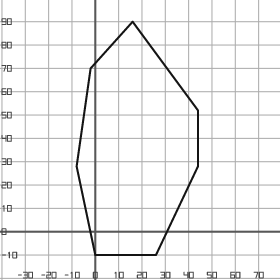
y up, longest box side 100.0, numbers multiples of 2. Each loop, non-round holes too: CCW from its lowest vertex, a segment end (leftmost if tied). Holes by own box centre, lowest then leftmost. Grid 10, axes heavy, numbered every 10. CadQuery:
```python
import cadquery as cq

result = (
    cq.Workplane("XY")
    .moveTo(0.0, -10.0)
    .lineTo(26.0, -10.0)
    .lineTo(44.0, 28.0)
    .lineTo(44.0, 52.0)
    .lineTo(16.0, 90.0)
    .lineTo(-2.0, 70.0)
    .lineTo(-8.0, 28.0)
    .close()
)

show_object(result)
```